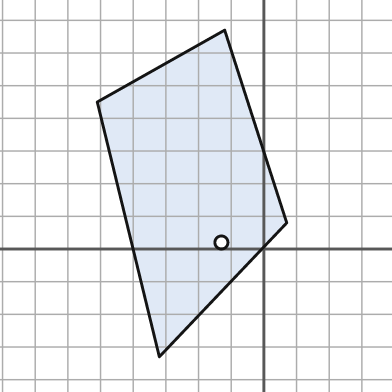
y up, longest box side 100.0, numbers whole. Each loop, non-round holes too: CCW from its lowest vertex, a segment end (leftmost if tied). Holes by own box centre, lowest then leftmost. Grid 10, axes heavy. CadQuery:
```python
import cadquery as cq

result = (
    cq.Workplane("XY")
    .moveTo(-32.0, -33.0)
    .lineTo(7.0, 8.0)
    .lineTo(-12.0, 67.0)
    .lineTo(-51.0, 45.0)
    .close()
    .moveTo(-13.0, 2.0)
    .circle(2.0)
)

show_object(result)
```